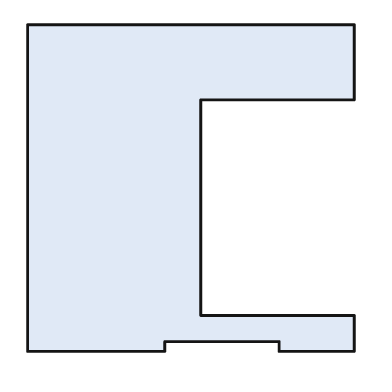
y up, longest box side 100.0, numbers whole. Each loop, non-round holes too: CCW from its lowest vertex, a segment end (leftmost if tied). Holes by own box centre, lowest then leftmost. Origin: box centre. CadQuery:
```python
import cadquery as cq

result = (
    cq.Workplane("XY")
    .moveTo(-50.0, -50.0)
    .lineTo(-8.0, -50.0)
    .lineTo(-8.0, -47.0)
    .lineTo(27.0, -47.0)
    .lineTo(27.0, -50.0)
    .lineTo(50.0, -50.0)
    .lineTo(50.0, -39.0)
    .lineTo(3.0, -39.0)
    .lineTo(3.0, 27.0)
    .lineTo(50.0, 27.0)
    .lineTo(50.0, 50.0)
    .lineTo(-50.0, 50.0)
    .close()
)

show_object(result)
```